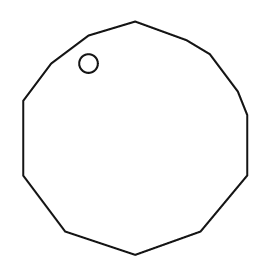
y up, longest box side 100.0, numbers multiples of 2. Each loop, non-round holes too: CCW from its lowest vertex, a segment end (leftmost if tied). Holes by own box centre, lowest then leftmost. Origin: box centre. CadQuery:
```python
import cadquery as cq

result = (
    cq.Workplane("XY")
    .moveTo(0.0, -50.0)
    .lineTo(28.0, -40.0)
    .lineTo(48.0, -16.0)
    .lineTo(48.0, 10.0)
    .lineTo(44.0, 20.0)
    .lineTo(32.0, 36.0)
    .lineTo(22.0, 42.0)
    .lineTo(0.0, 50.0)
    .lineTo(-20.0, 44.0)
    .lineTo(-36.0, 32.0)
    .lineTo(-48.0, 16.0)
    .lineTo(-48.0, -16.0)
    .lineTo(-30.0, -40.0)
    .close()
    .moveTo(-20.0, 32.0)
    .circle(4.0)
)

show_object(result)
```